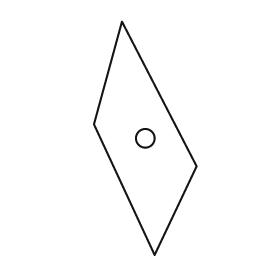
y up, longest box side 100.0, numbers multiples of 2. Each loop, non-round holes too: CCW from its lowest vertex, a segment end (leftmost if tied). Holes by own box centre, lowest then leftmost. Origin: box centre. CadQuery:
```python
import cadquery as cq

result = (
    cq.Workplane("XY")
    .moveTo(4.0, -50.0)
    .lineTo(22.0, -12.0)
    .lineTo(-10.0, 50.0)
    .lineTo(-22.0, 6.0)
    .close()
    .moveTo(0.0, 0.0)
    .circle(4.0)
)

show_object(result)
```